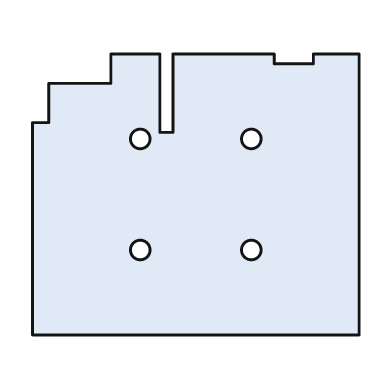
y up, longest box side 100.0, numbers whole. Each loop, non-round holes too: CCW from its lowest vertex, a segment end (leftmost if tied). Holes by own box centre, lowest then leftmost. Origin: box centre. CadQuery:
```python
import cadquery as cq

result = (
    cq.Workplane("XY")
    .moveTo(-50.0, -43.0)
    .lineTo(50.0, -43.0)
    .lineTo(50.0, 43.0)
    .lineTo(36.0, 43.0)
    .lineTo(36.0, 40.0)
    .lineTo(24.0, 40.0)
    .lineTo(24.0, 43.0)
    .lineTo(-7.0, 43.0)
    .lineTo(-7.0, 19.0)
    .lineTo(-11.0, 19.0)
    .lineTo(-11.0, 43.0)
    .lineTo(-26.0, 43.0)
    .lineTo(-26.0, 34.0)
    .lineTo(-45.0, 34.0)
    .lineTo(-45.0, 22.0)
    .lineTo(-50.0, 22.0)
    .close()
    .moveTo(-17.0, -17.0)
    .circle(3.0)
    .moveTo(17.0, -17.0)
    .circle(3.0)
    .moveTo(-17.0, 17.0)
    .circle(3.0)
    .moveTo(17.0, 17.0)
    .circle(3.0)
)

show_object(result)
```